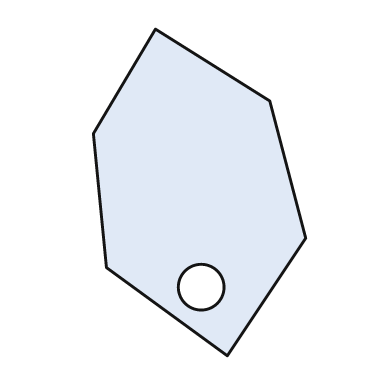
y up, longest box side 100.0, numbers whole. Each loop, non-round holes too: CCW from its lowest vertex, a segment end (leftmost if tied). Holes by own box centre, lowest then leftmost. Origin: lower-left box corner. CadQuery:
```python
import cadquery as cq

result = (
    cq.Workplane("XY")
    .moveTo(41.0, 0.0)
    .lineTo(65.0, 36.0)
    .lineTo(54.0, 78.0)
    .lineTo(19.0, 100.0)
    .lineTo(0.0, 68.0)
    .lineTo(4.0, 27.0)
    .close()
    .moveTo(33.0, 21.0)
    .circle(7.0)
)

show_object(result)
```